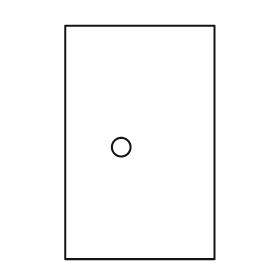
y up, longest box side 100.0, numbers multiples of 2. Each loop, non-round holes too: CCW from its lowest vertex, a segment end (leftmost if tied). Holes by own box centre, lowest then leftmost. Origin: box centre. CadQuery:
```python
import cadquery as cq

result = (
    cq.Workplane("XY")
    .moveTo(-32.0, -50.0)
    .lineTo(32.0, -50.0)
    .lineTo(32.0, 50.0)
    .lineTo(-32.0, 50.0)
    .close()
    .moveTo(-8.0, -2.0)
    .circle(4.0)
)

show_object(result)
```